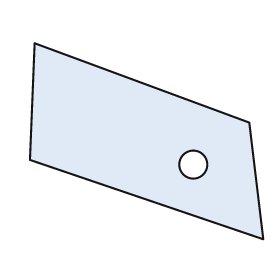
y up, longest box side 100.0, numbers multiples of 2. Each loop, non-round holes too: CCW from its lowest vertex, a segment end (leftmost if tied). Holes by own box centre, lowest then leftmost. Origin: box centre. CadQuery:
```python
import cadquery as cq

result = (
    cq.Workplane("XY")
    .moveTo(50.0, -42.0)
    .lineTo(44.0, 8.0)
    .lineTo(-48.0, 42.0)
    .lineTo(-50.0, -8.0)
    .close()
    .moveTo(20.0, -10.0)
    .circle(6.0)
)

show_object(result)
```